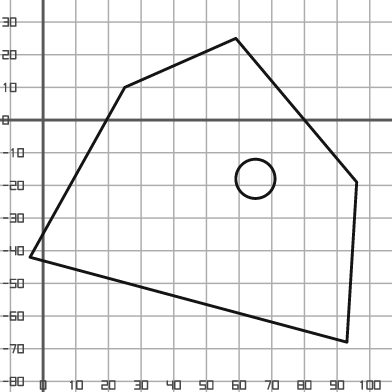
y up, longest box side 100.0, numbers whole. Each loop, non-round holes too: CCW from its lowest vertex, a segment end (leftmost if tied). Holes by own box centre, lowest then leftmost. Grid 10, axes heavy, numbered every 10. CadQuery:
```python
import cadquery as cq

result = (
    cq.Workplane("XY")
    .moveTo(93.0, -68.0)
    .lineTo(96.0, -19.0)
    .lineTo(59.0, 25.0)
    .lineTo(25.0, 10.0)
    .lineTo(-4.0, -42.0)
    .close()
    .moveTo(65.0, -18.0)
    .circle(6.0)
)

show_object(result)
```